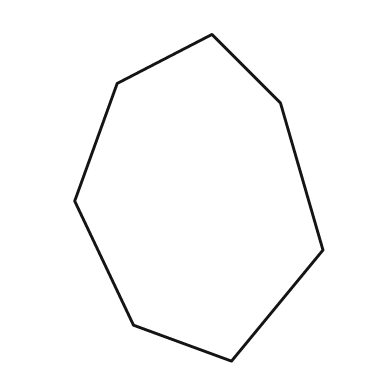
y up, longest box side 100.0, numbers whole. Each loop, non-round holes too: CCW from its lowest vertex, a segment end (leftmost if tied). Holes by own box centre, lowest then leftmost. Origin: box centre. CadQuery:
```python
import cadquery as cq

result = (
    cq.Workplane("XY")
    .moveTo(10.0, -50.0)
    .lineTo(38.0, -16.0)
    .lineTo(25.0, 29.0)
    .lineTo(4.0, 50.0)
    .lineTo(-25.0, 35.0)
    .lineTo(-38.0, -1.0)
    .lineTo(-20.0, -39.0)
    .close()
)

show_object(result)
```